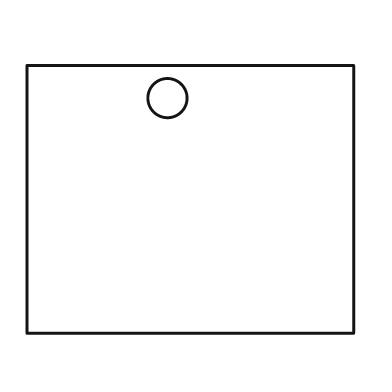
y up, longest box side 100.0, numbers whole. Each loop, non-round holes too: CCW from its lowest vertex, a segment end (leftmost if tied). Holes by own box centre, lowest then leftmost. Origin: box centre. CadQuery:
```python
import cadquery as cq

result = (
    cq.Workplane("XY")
    .moveTo(-50.0, -41.0)
    .lineTo(50.0, -41.0)
    .lineTo(50.0, 41.0)
    .lineTo(-50.0, 41.0)
    .close()
    .moveTo(-7.0, 31.0)
    .circle(6.0)
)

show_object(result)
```